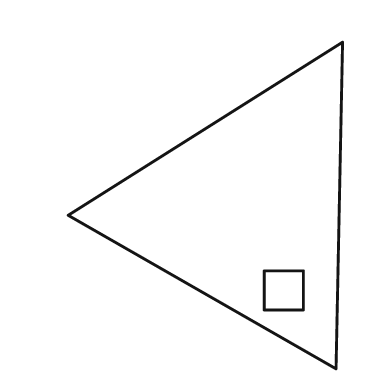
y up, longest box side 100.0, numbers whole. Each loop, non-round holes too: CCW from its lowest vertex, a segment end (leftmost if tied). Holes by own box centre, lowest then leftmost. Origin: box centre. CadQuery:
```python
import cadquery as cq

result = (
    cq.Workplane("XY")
    .moveTo(40.0, -50.0)
    .lineTo(42.0, 50.0)
    .lineTo(-42.0, -3.0)
    .close()
    .moveTo(18.0, -32.0)
    .lineTo(30.0, -32.0)
    .lineTo(30.0, -20.0)
    .lineTo(18.0, -20.0)
    .close()
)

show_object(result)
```